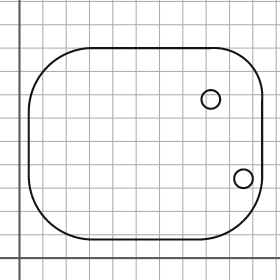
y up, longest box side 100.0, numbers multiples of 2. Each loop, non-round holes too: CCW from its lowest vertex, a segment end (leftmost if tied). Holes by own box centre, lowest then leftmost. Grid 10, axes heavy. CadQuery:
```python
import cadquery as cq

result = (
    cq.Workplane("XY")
    .moveTo(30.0, 8.0)
    .lineTo(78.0, 8.0)
    .threePointArc((96.0, 16.0), (104.0, 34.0))
    .lineTo(104.0, 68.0)
    .threePointArc((98.0, 84.0), (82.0, 90.0))
    .lineTo(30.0, 90.0)
    .threePointArc((12.0, 82.0), (4.0, 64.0))
    .lineTo(4.0, 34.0)
    .threePointArc((12.0, 16.0), (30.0, 8.0))
    .close()
    .moveTo(96.0, 34.0)
    .circle(4.0)
    .moveTo(82.0, 68.0)
    .circle(4.0)
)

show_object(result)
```